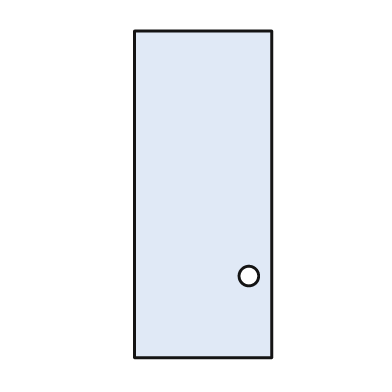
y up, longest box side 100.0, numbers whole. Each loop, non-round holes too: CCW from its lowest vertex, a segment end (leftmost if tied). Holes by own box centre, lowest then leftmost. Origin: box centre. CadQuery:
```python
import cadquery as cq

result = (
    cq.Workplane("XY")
    .moveTo(-21.0, -50.0)
    .lineTo(21.0, -50.0)
    .lineTo(21.0, 50.0)
    .lineTo(-21.0, 50.0)
    .close()
    .moveTo(14.0, -25.0)
    .circle(3.0)
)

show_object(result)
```